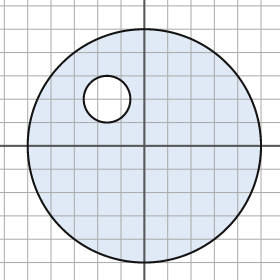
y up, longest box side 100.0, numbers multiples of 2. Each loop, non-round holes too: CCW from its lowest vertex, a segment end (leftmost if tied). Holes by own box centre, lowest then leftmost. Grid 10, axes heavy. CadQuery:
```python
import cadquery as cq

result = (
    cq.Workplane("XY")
    .moveTo(0.0, 0.0)
    .circle(50.0)
    .moveTo(-16.0, 20.0)
    .circle(10.0)
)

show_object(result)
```